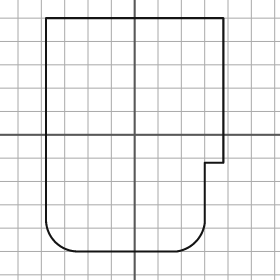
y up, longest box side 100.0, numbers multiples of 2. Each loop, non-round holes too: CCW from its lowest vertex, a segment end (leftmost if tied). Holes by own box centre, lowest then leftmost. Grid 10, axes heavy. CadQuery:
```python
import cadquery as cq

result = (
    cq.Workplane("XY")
    .moveTo(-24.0, -50.0)
    .lineTo(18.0, -50.0)
    .threePointArc((26.0, -46.0), (30.0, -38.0))
    .lineTo(30.0, -12.0)
    .lineTo(38.0, -12.0)
    .lineTo(38.0, 50.0)
    .lineTo(-38.0, 50.0)
    .lineTo(-38.0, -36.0)
    .threePointArc((-34.0, -46.0), (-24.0, -50.0))
    .close()
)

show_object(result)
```